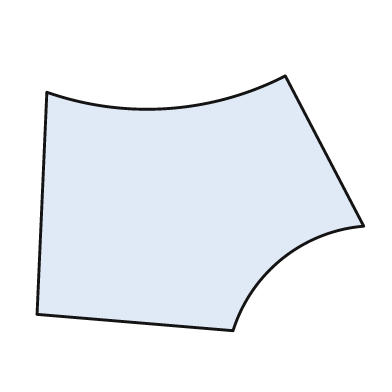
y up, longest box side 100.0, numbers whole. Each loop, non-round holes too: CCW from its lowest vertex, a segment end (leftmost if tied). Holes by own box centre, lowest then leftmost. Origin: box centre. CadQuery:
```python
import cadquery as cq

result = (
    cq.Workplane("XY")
    .moveTo(10.0, -39.0)
    .threePointArc((25.0, -17.0), (50.0, -7.0))
    .lineTo(26.0, 39.0)
    .threePointArc((-10.0, 29.0), (-47.0, 34.0))
    .lineTo(-50.0, -34.0)
    .close()
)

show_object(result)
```